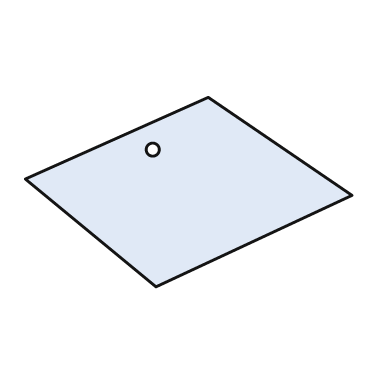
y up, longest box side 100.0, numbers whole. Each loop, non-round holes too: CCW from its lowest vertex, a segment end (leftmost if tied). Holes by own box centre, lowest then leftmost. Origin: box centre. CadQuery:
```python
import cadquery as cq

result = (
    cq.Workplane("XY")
    .moveTo(-10.0, -29.0)
    .lineTo(50.0, -1.0)
    .lineTo(6.0, 29.0)
    .lineTo(-50.0, 4.0)
    .close()
    .moveTo(-11.0, 13.0)
    .circle(2.0)
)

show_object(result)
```